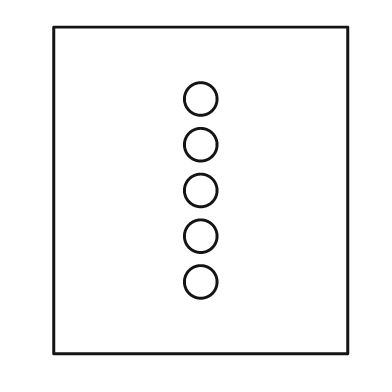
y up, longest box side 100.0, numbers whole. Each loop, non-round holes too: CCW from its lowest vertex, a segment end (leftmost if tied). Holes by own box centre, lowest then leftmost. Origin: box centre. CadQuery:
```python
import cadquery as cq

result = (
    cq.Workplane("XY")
    .moveTo(-45.0, -50.0)
    .lineTo(45.0, -50.0)
    .lineTo(45.0, 50.0)
    .lineTo(-45.0, 50.0)
    .close()
    .moveTo(0.0, -28.0)
    .circle(5.0)
    .moveTo(0.0, -14.0)
    .circle(5.0)
    .moveTo(0.0, 0.0)
    .circle(5.0)
    .moveTo(0.0, 14.0)
    .circle(5.0)
    .moveTo(0.0, 28.0)
    .circle(5.0)
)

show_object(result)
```